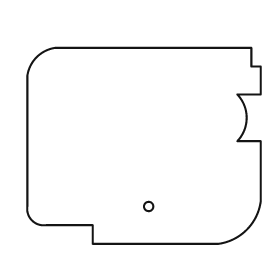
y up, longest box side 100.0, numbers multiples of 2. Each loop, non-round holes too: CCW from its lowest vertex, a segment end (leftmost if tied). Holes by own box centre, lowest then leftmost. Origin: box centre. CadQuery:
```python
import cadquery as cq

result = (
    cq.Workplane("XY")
    .moveTo(-22.0, -42.0)
    .lineTo(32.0, -42.0)
    .threePointArc((44.0, -36.0), (50.0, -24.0))
    .lineTo(50.0, 2.0)
    .lineTo(40.0, 2.0)
    .threePointArc((44.0, 12.0), (40.0, 22.0))
    .lineTo(50.0, 22.0)
    .lineTo(50.0, 34.0)
    .lineTo(46.0, 34.0)
    .lineTo(46.0, 42.0)
    .lineTo(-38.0, 42.0)
    .threePointArc((-46.0, 38.0), (-50.0, 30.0))
    .lineTo(-50.0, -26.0)
    .threePointArc((-48.0, -32.0), (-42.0, -34.0))
    .lineTo(-22.0, -34.0)
    .close()
    .moveTo(2.0, -26.0)
    .circle(2.0)
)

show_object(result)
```